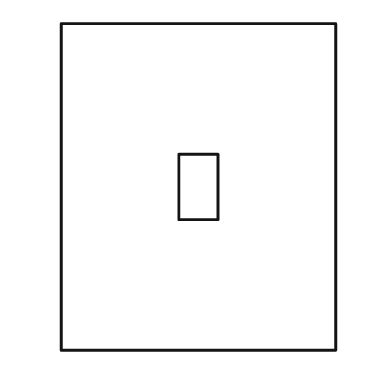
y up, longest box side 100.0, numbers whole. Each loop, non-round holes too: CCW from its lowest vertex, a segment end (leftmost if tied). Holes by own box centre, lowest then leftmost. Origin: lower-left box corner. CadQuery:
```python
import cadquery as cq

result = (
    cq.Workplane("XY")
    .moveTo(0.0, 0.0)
    .lineTo(84.0, 0.0)
    .lineTo(84.0, 100.0)
    .lineTo(0.0, 100.0)
    .close()
    .moveTo(36.0, 40.0)
    .lineTo(48.0, 40.0)
    .lineTo(48.0, 60.0)
    .lineTo(36.0, 60.0)
    .close()
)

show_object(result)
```